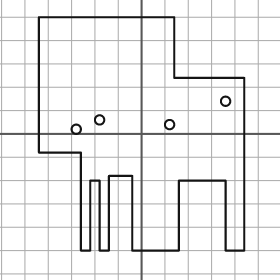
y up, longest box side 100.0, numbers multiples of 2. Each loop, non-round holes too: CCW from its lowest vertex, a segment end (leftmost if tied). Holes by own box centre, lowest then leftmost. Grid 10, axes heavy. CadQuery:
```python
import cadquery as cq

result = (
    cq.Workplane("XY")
    .moveTo(-26.0, -50.0)
    .lineTo(-22.0, -50.0)
    .lineTo(-22.0, -20.0)
    .lineTo(-18.0, -20.0)
    .lineTo(-18.0, -50.0)
    .lineTo(-14.0, -50.0)
    .lineTo(-14.0, -18.0)
    .lineTo(-4.0, -18.0)
    .lineTo(-4.0, -50.0)
    .lineTo(16.0, -50.0)
    .lineTo(16.0, -20.0)
    .lineTo(36.0, -20.0)
    .lineTo(36.0, -50.0)
    .lineTo(44.0, -50.0)
    .lineTo(44.0, 24.0)
    .lineTo(14.0, 24.0)
    .lineTo(14.0, 50.0)
    .lineTo(-44.0, 50.0)
    .lineTo(-44.0, -8.0)
    .lineTo(-26.0, -8.0)
    .close()
    .moveTo(-28.0, 2.0)
    .circle(2.0)
    .moveTo(12.0, 4.0)
    .circle(2.0)
    .moveTo(-18.0, 6.0)
    .circle(2.0)
    .moveTo(36.0, 14.0)
    .circle(2.0)
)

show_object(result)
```